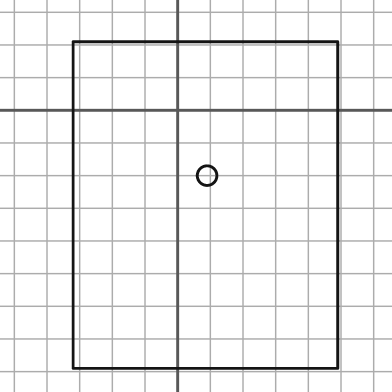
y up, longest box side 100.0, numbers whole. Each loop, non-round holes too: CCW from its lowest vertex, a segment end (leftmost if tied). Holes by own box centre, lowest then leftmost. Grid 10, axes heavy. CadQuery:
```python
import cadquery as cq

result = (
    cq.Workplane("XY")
    .moveTo(-32.0, -79.0)
    .lineTo(49.0, -79.0)
    .lineTo(49.0, 21.0)
    .lineTo(-32.0, 21.0)
    .close()
    .moveTo(9.0, -20.0)
    .circle(3.0)
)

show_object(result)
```